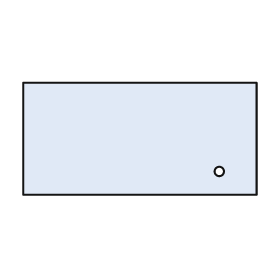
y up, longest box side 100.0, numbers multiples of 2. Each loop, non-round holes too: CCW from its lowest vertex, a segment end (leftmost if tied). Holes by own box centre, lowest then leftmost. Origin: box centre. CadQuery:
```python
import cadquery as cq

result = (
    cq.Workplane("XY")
    .moveTo(-50.0, -24.0)
    .lineTo(50.0, -24.0)
    .lineTo(50.0, 24.0)
    .lineTo(-50.0, 24.0)
    .close()
    .moveTo(34.0, -14.0)
    .circle(2.0)
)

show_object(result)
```